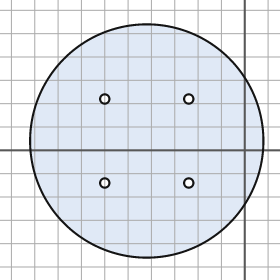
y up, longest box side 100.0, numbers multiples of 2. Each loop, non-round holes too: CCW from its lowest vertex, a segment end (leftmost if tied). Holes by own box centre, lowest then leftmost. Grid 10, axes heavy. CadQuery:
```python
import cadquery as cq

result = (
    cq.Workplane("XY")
    .moveTo(-42.0, 4.0)
    .circle(50.0)
    .moveTo(-60.0, -14.0)
    .circle(2.0)
    .moveTo(-24.0, -14.0)
    .circle(2.0)
    .moveTo(-60.0, 22.0)
    .circle(2.0)
    .moveTo(-24.0, 22.0)
    .circle(2.0)
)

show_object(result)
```